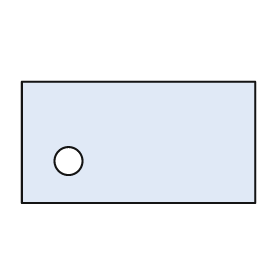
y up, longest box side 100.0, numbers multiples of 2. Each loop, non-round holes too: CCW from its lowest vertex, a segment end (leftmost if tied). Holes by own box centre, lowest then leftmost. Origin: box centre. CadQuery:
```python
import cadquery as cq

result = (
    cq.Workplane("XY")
    .moveTo(-50.0, -26.0)
    .lineTo(50.0, -26.0)
    .lineTo(50.0, 26.0)
    .lineTo(-50.0, 26.0)
    .close()
    .moveTo(-30.0, -8.0)
    .circle(6.0)
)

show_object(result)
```